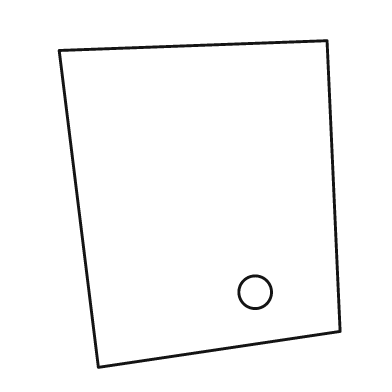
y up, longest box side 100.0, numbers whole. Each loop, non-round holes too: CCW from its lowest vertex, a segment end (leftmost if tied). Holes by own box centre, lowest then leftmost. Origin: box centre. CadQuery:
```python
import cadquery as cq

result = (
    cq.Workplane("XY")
    .moveTo(-31.0, -50.0)
    .lineTo(43.0, -39.0)
    .lineTo(39.0, 50.0)
    .lineTo(-43.0, 47.0)
    .close()
    .moveTo(17.0, -27.0)
    .circle(5.0)
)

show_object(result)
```